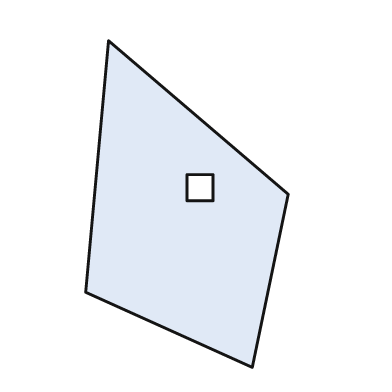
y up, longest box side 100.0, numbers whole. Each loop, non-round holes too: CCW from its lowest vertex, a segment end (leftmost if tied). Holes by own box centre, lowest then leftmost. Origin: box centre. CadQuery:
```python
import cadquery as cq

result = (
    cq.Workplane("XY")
    .moveTo(20.0, -50.0)
    .lineTo(31.0, 3.0)
    .lineTo(-24.0, 50.0)
    .lineTo(-31.0, -27.0)
    .close()
    .moveTo(0.0, 1.0)
    .lineTo(8.0, 1.0)
    .lineTo(8.0, 9.0)
    .lineTo(0.0, 9.0)
    .close()
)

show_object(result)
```